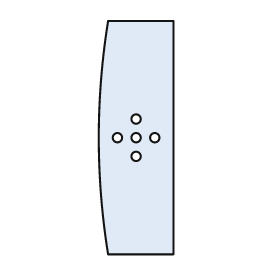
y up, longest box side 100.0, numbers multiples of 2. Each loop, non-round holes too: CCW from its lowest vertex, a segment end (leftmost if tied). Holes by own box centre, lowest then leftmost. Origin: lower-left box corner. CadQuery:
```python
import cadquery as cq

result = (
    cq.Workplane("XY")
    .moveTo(4.0, 0.0)
    .lineTo(32.0, 0.0)
    .lineTo(32.0, 100.0)
    .lineTo(4.0, 100.0)
    .threePointArc((0.0, 50.0), (4.0, 0.0))
    .close()
    .moveTo(16.0, 42.0)
    .circle(2.0)
    .moveTo(8.0, 50.0)
    .circle(2.0)
    .moveTo(16.0, 50.0)
    .circle(2.0)
    .moveTo(24.0, 50.0)
    .circle(2.0)
    .moveTo(16.0, 58.0)
    .circle(2.0)
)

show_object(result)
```